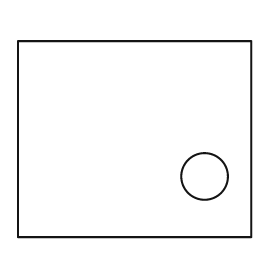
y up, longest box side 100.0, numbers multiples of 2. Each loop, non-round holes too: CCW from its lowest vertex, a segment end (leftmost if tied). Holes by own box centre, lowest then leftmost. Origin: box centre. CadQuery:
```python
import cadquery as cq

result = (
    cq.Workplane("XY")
    .moveTo(-50.0, -42.0)
    .lineTo(50.0, -42.0)
    .lineTo(50.0, 42.0)
    .lineTo(-50.0, 42.0)
    .close()
    .moveTo(30.0, -16.0)
    .circle(10.0)
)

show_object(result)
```